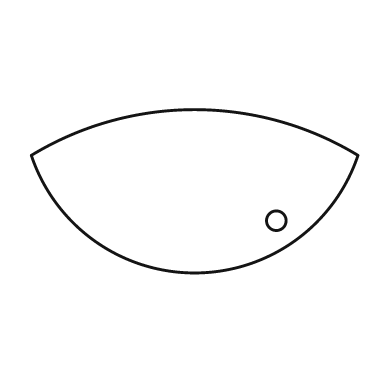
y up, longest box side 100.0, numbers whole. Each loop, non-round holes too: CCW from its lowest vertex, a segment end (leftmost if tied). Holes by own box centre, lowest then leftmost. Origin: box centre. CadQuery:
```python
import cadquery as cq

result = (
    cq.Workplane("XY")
    .moveTo(-50.0, 11.0)
    .threePointArc((0.0, -25.0), (50.0, 11.0))
    .threePointArc((0.0, 25.0), (-50.0, 11.0))
    .close()
    .moveTo(25.0, -9.0)
    .circle(3.0)
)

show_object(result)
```